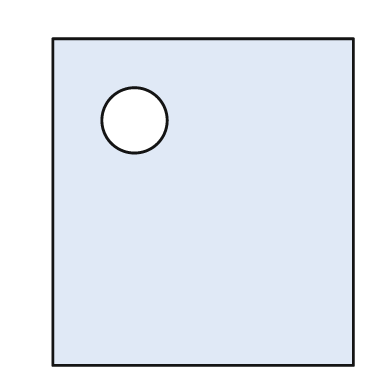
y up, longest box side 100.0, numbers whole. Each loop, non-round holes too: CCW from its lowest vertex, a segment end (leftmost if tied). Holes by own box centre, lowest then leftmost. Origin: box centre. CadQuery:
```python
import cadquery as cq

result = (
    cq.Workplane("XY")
    .moveTo(-46.0, -50.0)
    .lineTo(46.0, -50.0)
    .lineTo(46.0, 50.0)
    .lineTo(-46.0, 50.0)
    .close()
    .moveTo(-21.0, 25.0)
    .circle(10.0)
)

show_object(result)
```